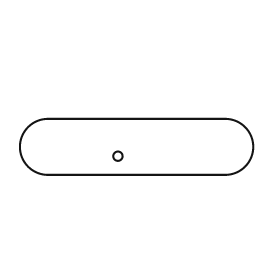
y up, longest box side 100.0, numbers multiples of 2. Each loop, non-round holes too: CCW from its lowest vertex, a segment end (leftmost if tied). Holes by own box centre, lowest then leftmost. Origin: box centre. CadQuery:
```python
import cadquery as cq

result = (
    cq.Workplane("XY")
    .moveTo(-38.0, -12.0)
    .lineTo(38.0, -12.0)
    .threePointArc((50.0, 0.0), (38.0, 12.0))
    .lineTo(-38.0, 12.0)
    .threePointArc((-50.0, 0.0), (-38.0, -12.0))
    .close()
    .moveTo(-8.0, -4.0)
    .circle(2.0)
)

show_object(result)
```